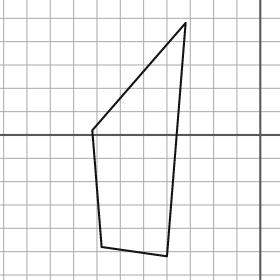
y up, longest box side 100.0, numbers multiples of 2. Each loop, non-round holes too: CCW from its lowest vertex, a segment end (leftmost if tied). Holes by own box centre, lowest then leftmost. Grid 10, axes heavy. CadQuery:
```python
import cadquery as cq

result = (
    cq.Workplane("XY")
    .moveTo(-40.0, -52.0)
    .lineTo(-32.0, 48.0)
    .lineTo(-72.0, 2.0)
    .lineTo(-68.0, -48.0)
    .close()
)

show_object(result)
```